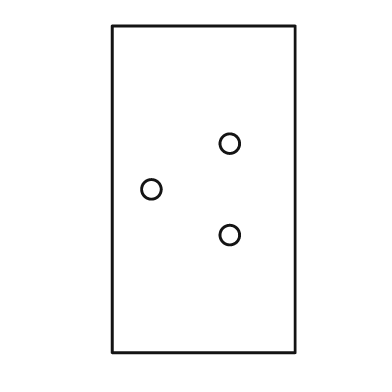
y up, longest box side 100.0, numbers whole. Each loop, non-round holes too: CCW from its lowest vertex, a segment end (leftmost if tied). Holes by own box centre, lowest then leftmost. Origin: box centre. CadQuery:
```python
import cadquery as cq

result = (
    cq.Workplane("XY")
    .moveTo(-28.0, -50.0)
    .lineTo(28.0, -50.0)
    .lineTo(28.0, 50.0)
    .lineTo(-28.0, 50.0)
    .close()
    .moveTo(8.0, -14.0)
    .circle(3.0)
    .moveTo(-16.0, 0.0)
    .circle(3.0)
    .moveTo(8.0, 14.0)
    .circle(3.0)
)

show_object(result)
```